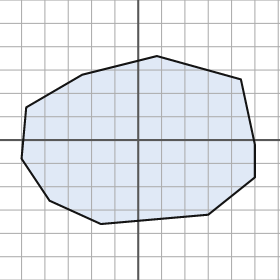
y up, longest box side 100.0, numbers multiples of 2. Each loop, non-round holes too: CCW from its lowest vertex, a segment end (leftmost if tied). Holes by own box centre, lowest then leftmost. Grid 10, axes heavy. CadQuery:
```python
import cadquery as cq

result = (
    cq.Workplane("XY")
    .moveTo(-16.0, -36.0)
    .lineTo(30.0, -32.0)
    .lineTo(50.0, -16.0)
    .lineTo(50.0, -2.0)
    .lineTo(44.0, 26.0)
    .lineTo(8.0, 36.0)
    .lineTo(-24.0, 28.0)
    .lineTo(-48.0, 14.0)
    .lineTo(-50.0, -8.0)
    .lineTo(-38.0, -26.0)
    .close()
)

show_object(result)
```